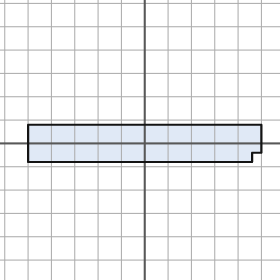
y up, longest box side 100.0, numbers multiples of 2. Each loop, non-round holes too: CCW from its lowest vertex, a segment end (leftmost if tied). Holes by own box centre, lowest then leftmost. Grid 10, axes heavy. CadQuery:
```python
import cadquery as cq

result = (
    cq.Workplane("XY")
    .moveTo(-50.0, -8.0)
    .lineTo(46.0, -8.0)
    .lineTo(46.0, -4.0)
    .lineTo(50.0, -4.0)
    .lineTo(50.0, 8.0)
    .lineTo(-50.0, 8.0)
    .close()
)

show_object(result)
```